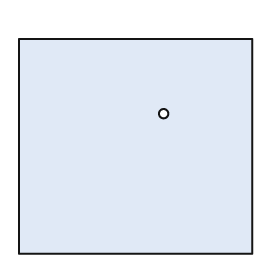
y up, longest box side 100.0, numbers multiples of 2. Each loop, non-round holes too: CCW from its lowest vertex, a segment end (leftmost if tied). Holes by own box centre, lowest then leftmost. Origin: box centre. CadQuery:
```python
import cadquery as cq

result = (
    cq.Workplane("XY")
    .moveTo(-50.0, -46.0)
    .lineTo(50.0, -46.0)
    .lineTo(50.0, 46.0)
    .lineTo(-50.0, 46.0)
    .close()
    .moveTo(12.0, 14.0)
    .circle(2.0)
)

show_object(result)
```